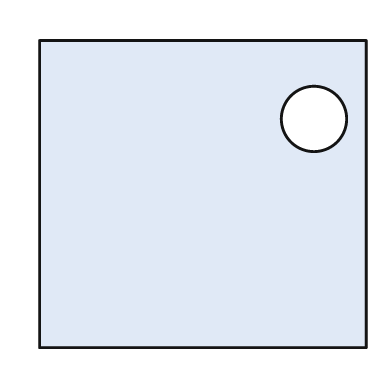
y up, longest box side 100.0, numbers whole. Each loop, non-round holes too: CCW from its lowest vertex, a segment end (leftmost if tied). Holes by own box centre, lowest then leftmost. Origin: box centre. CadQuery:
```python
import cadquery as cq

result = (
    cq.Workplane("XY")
    .moveTo(-50.0, -47.0)
    .lineTo(50.0, -47.0)
    .lineTo(50.0, 47.0)
    .lineTo(-50.0, 47.0)
    .close()
    .moveTo(34.0, 23.0)
    .circle(10.0)
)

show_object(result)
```